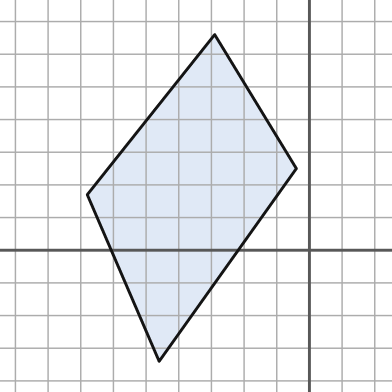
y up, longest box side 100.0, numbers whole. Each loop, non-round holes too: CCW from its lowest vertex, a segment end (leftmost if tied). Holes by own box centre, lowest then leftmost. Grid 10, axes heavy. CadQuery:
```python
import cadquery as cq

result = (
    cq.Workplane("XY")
    .moveTo(-46.0, -34.0)
    .lineTo(-4.0, 25.0)
    .lineTo(-29.0, 66.0)
    .lineTo(-68.0, 17.0)
    .close()
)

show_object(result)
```